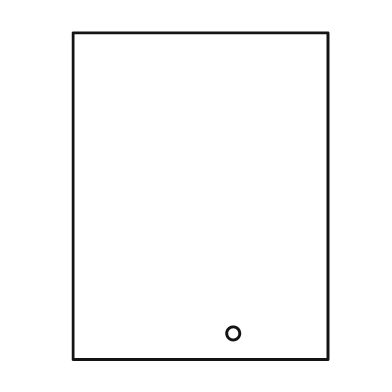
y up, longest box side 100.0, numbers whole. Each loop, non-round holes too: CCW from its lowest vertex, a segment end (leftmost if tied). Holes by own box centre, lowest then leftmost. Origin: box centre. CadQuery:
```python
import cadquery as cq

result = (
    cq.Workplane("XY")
    .moveTo(-39.0, -50.0)
    .lineTo(39.0, -50.0)
    .lineTo(39.0, 50.0)
    .lineTo(-39.0, 50.0)
    .close()
    .moveTo(10.0, -42.0)
    .circle(2.0)
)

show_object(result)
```